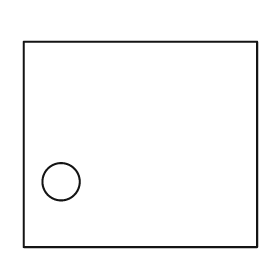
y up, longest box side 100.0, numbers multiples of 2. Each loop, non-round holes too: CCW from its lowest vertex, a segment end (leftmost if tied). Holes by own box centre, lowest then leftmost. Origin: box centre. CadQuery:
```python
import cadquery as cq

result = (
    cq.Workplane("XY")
    .moveTo(-50.0, -44.0)
    .lineTo(50.0, -44.0)
    .lineTo(50.0, 44.0)
    .lineTo(-50.0, 44.0)
    .close()
    .moveTo(-34.0, -16.0)
    .circle(8.0)
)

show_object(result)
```